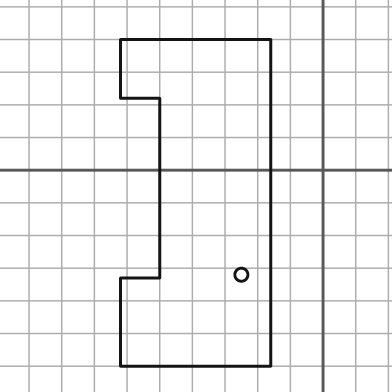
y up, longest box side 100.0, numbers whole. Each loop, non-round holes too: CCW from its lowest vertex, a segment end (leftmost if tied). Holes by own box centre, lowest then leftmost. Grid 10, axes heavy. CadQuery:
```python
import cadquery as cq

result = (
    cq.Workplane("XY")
    .moveTo(-62.0, -60.0)
    .lineTo(-16.0, -60.0)
    .lineTo(-16.0, 40.0)
    .lineTo(-62.0, 40.0)
    .lineTo(-62.0, 22.0)
    .lineTo(-50.0, 22.0)
    .lineTo(-50.0, -33.0)
    .lineTo(-62.0, -33.0)
    .close()
    .moveTo(-25.0, -32.0)
    .circle(2.0)
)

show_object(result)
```